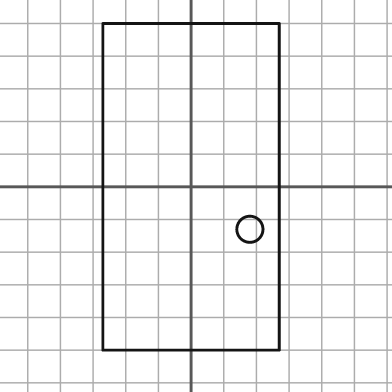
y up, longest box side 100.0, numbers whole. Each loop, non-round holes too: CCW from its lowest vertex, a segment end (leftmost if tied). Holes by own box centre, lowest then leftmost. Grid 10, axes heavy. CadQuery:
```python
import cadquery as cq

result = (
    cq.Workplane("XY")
    .moveTo(-27.0, -50.0)
    .lineTo(27.0, -50.0)
    .lineTo(27.0, 50.0)
    .lineTo(-27.0, 50.0)
    .close()
    .moveTo(18.0, -13.0)
    .circle(4.0)
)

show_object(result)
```